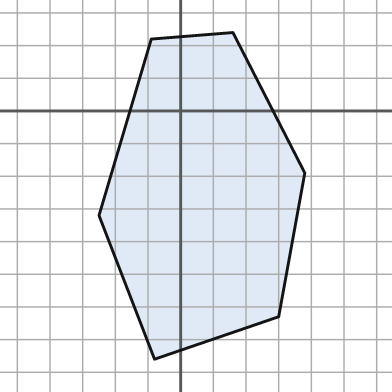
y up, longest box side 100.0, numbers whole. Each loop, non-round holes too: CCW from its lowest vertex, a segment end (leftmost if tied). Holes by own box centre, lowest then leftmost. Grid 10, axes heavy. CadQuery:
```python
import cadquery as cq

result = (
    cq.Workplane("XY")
    .moveTo(-8.0, -76.0)
    .lineTo(30.0, -63.0)
    .lineTo(38.0, -19.0)
    .lineTo(16.0, 24.0)
    .lineTo(-9.0, 22.0)
    .lineTo(-25.0, -32.0)
    .close()
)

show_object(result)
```